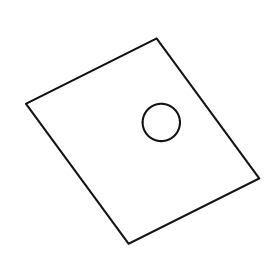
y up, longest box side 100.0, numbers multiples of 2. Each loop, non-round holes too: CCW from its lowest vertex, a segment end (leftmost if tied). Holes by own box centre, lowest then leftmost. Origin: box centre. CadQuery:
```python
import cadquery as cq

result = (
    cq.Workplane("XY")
    .moveTo(-6.0, -44.0)
    .lineTo(50.0, -16.0)
    .lineTo(6.0, 44.0)
    .lineTo(-50.0, 16.0)
    .close()
    .moveTo(8.0, 8.0)
    .circle(8.0)
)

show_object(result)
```